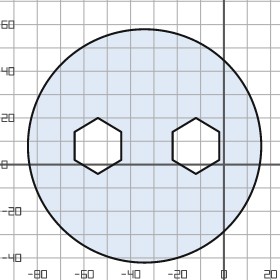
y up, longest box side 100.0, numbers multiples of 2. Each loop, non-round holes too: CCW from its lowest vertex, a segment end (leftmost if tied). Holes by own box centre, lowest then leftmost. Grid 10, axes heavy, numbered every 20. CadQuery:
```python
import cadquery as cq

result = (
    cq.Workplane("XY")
    .moveTo(-34.0, 8.0)
    .circle(50.0)
    .moveTo(-54.0, -4.0)
    .lineTo(-44.0, 2.0)
    .lineTo(-44.0, 14.0)
    .lineTo(-54.0, 20.0)
    .lineTo(-64.0, 14.0)
    .lineTo(-64.0, 2.0)
    .close()
    .moveTo(-12.0, -4.0)
    .lineTo(-2.0, 2.0)
    .lineTo(-2.0, 14.0)
    .lineTo(-12.0, 20.0)
    .lineTo(-22.0, 14.0)
    .lineTo(-22.0, 2.0)
    .close()
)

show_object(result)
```